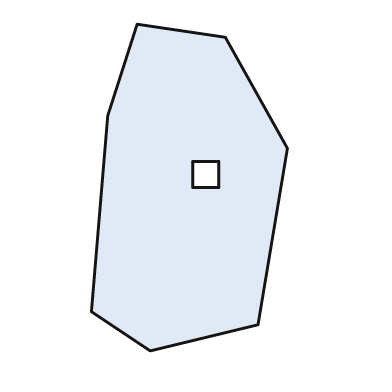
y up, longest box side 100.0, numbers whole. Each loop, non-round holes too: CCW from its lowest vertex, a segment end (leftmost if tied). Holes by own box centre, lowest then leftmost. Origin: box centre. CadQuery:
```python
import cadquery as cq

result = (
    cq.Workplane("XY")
    .moveTo(-12.0, -50.0)
    .lineTo(21.0, -42.0)
    .lineTo(30.0, 12.0)
    .lineTo(11.0, 46.0)
    .lineTo(-16.0, 50.0)
    .lineTo(-25.0, 22.0)
    .lineTo(-30.0, -38.0)
    .close()
    .moveTo(1.0, 0.0)
    .lineTo(9.0, 0.0)
    .lineTo(9.0, 8.0)
    .lineTo(1.0, 8.0)
    .close()
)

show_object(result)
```